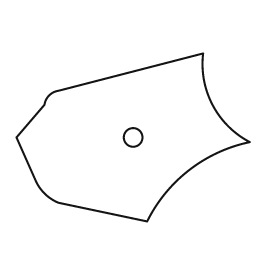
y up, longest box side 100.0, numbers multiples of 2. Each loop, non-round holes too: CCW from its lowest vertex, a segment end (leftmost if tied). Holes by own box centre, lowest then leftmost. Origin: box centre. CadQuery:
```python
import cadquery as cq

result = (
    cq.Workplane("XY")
    .moveTo(6.0, -36.0)
    .threePointArc((24.0, -14.0), (50.0, -2.0))
    .threePointArc((34.0, 14.0), (30.0, 36.0))
    .lineTo(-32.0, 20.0)
    .threePointArc((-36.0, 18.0), (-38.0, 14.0))
    .lineTo(-50.0, 0.0)
    .lineTo(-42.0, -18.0)
    .threePointArc((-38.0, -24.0), (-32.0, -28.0))
    .close()
    .moveTo(0.0, 0.0)
    .circle(4.0)
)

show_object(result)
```